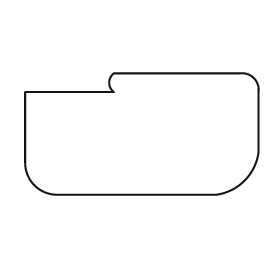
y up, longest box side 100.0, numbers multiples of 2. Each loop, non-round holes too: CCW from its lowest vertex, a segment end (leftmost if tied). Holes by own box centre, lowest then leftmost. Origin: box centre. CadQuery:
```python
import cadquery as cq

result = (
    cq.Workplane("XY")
    .moveTo(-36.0, -26.0)
    .lineTo(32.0, -26.0)
    .threePointArc((44.0, -20.0), (50.0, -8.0))
    .lineTo(50.0, 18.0)
    .threePointArc((48.0, 24.0), (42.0, 26.0))
    .lineTo(-12.0, 26.0)
    .threePointArc((-14.0, 22.0), (-12.0, 18.0))
    .lineTo(-50.0, 18.0)
    .lineTo(-50.0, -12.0)
    .threePointArc((-46.0, -22.0), (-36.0, -26.0))
    .close()
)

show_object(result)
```